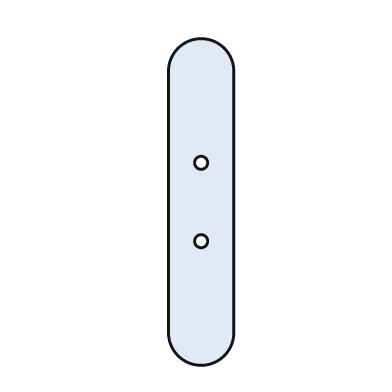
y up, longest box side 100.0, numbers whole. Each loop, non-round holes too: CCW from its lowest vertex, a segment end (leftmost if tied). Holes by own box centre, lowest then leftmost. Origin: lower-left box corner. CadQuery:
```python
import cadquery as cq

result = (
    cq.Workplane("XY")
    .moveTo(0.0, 10.0)
    .threePointArc((10.0, 0.0), (20.0, 10.0))
    .lineTo(20.0, 90.0)
    .threePointArc((10.0, 100.0), (0.0, 90.0))
    .close()
    .moveTo(10.0, 38.0)
    .circle(2.0)
    .moveTo(10.0, 62.0)
    .circle(2.0)
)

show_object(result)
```